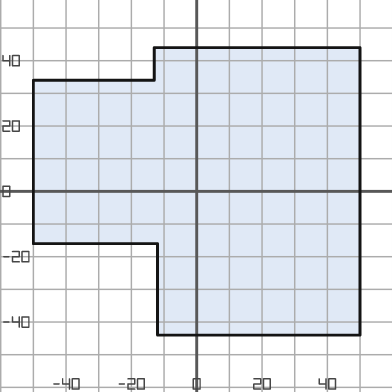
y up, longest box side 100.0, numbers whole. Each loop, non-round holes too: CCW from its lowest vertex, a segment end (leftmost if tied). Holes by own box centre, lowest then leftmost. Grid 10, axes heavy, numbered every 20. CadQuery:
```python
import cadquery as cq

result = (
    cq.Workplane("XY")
    .moveTo(-12.0, -44.0)
    .lineTo(50.0, -44.0)
    .lineTo(50.0, 44.0)
    .lineTo(-13.0, 44.0)
    .lineTo(-13.0, 34.0)
    .lineTo(-50.0, 34.0)
    .lineTo(-50.0, -16.0)
    .lineTo(-12.0, -16.0)
    .close()
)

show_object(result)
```